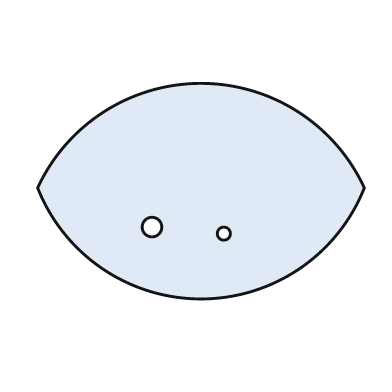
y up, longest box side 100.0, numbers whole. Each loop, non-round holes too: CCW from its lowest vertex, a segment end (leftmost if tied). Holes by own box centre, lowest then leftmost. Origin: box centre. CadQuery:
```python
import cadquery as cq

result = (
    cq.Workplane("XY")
    .moveTo(-50.0, 1.0)
    .threePointArc((0.0, -33.0), (50.0, 1.0))
    .threePointArc((0.0, 33.0), (-50.0, 1.0))
    .close()
    .moveTo(7.0, -13.0)
    .circle(2.0)
    .moveTo(-15.0, -11.0)
    .circle(3.0)
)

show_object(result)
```